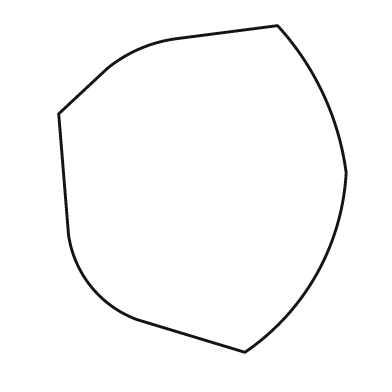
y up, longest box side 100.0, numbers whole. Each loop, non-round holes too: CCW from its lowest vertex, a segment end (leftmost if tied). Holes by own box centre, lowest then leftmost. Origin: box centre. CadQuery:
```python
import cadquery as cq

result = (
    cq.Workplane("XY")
    .moveTo(13.0, -50.0)
    .threePointArc((35.0, -26.0), (44.0, 5.0))
    .threePointArc((37.0, 29.0), (23.0, 50.0))
    .lineTo(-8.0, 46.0)
    .threePointArc((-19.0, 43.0), (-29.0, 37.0))
    .lineTo(-44.0, 23.0)
    .lineTo(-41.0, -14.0)
    .threePointArc((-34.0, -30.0), (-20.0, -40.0))
    .close()
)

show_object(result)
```